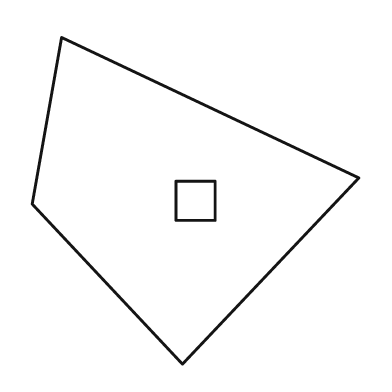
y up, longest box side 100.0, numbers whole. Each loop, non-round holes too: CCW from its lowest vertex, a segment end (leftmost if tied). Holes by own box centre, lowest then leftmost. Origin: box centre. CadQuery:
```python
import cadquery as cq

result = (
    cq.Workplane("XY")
    .moveTo(-4.0, -50.0)
    .lineTo(50.0, 7.0)
    .lineTo(-41.0, 50.0)
    .lineTo(-50.0, -1.0)
    .close()
    .moveTo(-6.0, -6.0)
    .lineTo(6.0, -6.0)
    .lineTo(6.0, 6.0)
    .lineTo(-6.0, 6.0)
    .close()
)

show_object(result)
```